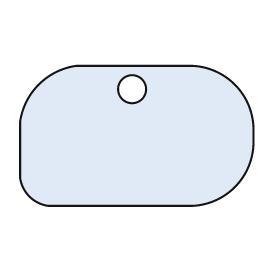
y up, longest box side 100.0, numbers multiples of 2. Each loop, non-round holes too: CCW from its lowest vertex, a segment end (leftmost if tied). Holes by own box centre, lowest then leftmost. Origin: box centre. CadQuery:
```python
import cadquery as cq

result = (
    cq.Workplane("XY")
    .moveTo(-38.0, -30.0)
    .lineTo(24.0, -30.0)
    .threePointArc((42.0, -22.0), (50.0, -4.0))
    .lineTo(50.0, 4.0)
    .threePointArc((42.0, 22.0), (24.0, 30.0))
    .lineTo(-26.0, 30.0)
    .threePointArc((-42.0, 22.0), (-50.0, 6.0))
    .lineTo(-50.0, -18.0)
    .threePointArc((-46.0, -26.0), (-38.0, -30.0))
    .close()
    .moveTo(-2.0, 20.0)
    .circle(6.0)
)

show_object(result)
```